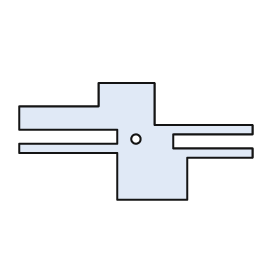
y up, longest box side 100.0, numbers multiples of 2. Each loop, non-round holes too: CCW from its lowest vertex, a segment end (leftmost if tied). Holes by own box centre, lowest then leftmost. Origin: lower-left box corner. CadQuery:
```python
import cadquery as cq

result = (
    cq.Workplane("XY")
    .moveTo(42.0, 0.0)
    .lineTo(72.0, 0.0)
    .lineTo(72.0, 18.0)
    .lineTo(100.0, 18.0)
    .lineTo(100.0, 22.0)
    .lineTo(66.0, 22.0)
    .lineTo(66.0, 28.0)
    .lineTo(100.0, 28.0)
    .lineTo(100.0, 32.0)
    .lineTo(58.0, 32.0)
    .lineTo(58.0, 50.0)
    .lineTo(34.0, 50.0)
    .lineTo(34.0, 40.0)
    .lineTo(0.0, 40.0)
    .lineTo(0.0, 30.0)
    .lineTo(42.0, 30.0)
    .lineTo(42.0, 24.0)
    .lineTo(0.0, 24.0)
    .lineTo(0.0, 20.0)
    .lineTo(42.0, 20.0)
    .close()
    .moveTo(50.0, 26.0)
    .circle(2.0)
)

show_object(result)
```